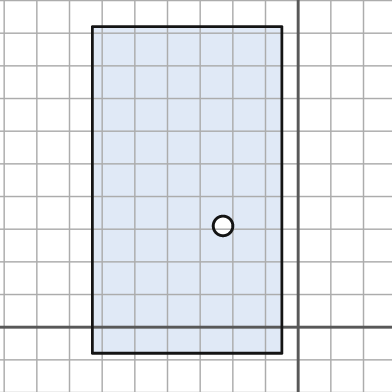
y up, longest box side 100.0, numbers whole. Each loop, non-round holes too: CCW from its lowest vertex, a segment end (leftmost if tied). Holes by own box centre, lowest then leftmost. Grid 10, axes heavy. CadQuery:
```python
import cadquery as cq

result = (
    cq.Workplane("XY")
    .moveTo(-63.0, -8.0)
    .lineTo(-5.0, -8.0)
    .lineTo(-5.0, 92.0)
    .lineTo(-63.0, 92.0)
    .close()
    .moveTo(-23.0, 31.0)
    .circle(3.0)
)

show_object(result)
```